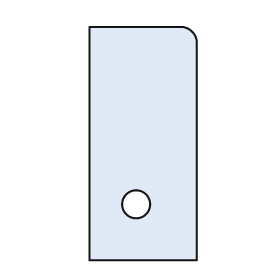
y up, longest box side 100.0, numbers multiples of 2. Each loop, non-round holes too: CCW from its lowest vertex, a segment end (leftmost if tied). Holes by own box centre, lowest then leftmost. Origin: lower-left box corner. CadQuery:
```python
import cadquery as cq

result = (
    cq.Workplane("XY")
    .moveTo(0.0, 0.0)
    .lineTo(46.0, 0.0)
    .lineTo(46.0, 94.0)
    .threePointArc((44.0, 98.0), (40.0, 100.0))
    .lineTo(0.0, 100.0)
    .close()
    .moveTo(20.0, 24.0)
    .circle(6.0)
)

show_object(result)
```